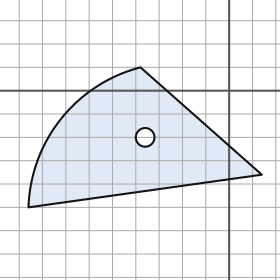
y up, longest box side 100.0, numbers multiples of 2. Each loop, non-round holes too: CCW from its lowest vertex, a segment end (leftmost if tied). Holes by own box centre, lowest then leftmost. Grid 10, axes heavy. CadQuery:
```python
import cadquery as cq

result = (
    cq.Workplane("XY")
    .moveTo(-86.0, -50.0)
    .lineTo(14.0, -36.0)
    .lineTo(-38.0, 10.0)
    .threePointArc((-72.0, -12.0), (-86.0, -50.0))
    .close()
    .moveTo(-36.0, -20.0)
    .circle(4.0)
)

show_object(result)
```